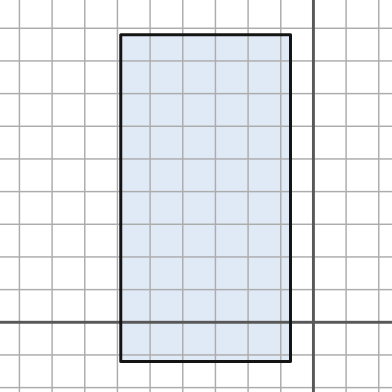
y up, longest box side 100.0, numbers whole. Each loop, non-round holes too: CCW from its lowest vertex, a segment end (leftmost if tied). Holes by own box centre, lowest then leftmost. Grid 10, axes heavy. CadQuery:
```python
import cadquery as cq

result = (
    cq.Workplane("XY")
    .moveTo(-59.0, -12.0)
    .lineTo(-7.0, -12.0)
    .lineTo(-7.0, 88.0)
    .lineTo(-59.0, 88.0)
    .close()
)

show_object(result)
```